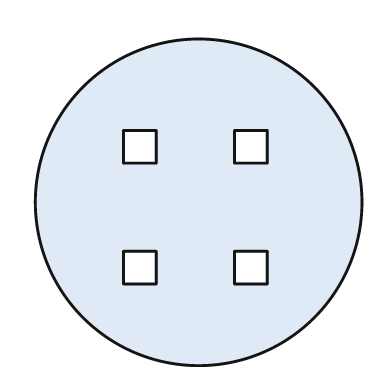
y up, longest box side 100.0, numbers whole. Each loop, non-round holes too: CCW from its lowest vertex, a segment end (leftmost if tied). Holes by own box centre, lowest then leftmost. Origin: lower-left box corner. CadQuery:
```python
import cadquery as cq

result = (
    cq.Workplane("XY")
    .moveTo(50.0, 50.0)
    .circle(50.0)
    .moveTo(27.0, 25.0)
    .lineTo(37.0, 25.0)
    .lineTo(37.0, 35.0)
    .lineTo(27.0, 35.0)
    .close()
    .moveTo(61.0, 25.0)
    .lineTo(71.0, 25.0)
    .lineTo(71.0, 35.0)
    .lineTo(61.0, 35.0)
    .close()
    .moveTo(27.0, 62.0)
    .lineTo(37.0, 62.0)
    .lineTo(37.0, 72.0)
    .lineTo(27.0, 72.0)
    .close()
    .moveTo(61.0, 62.0)
    .lineTo(71.0, 62.0)
    .lineTo(71.0, 72.0)
    .lineTo(61.0, 72.0)
    .close()
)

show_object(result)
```